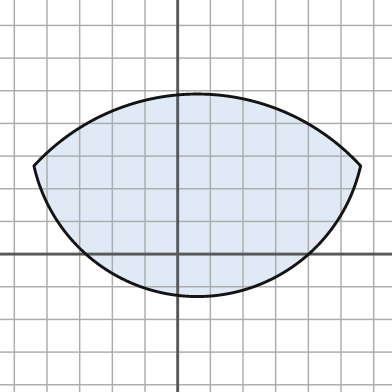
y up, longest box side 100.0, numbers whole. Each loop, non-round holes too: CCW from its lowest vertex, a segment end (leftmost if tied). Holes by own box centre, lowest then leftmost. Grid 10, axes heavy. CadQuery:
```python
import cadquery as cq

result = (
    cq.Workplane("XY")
    .moveTo(-44.0, 27.0)
    .threePointArc((6.0, -13.0), (56.0, 27.0))
    .threePointArc((6.0, 49.0), (-44.0, 27.0))
    .close()
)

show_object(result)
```